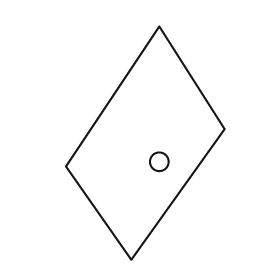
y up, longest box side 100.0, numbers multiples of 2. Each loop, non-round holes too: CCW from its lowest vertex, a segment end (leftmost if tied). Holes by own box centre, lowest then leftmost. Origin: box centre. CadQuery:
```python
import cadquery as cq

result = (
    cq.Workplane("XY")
    .moveTo(-6.0, -50.0)
    .lineTo(34.0, 6.0)
    .lineTo(6.0, 50.0)
    .lineTo(-34.0, -10.0)
    .close()
    .moveTo(6.0, -8.0)
    .circle(4.0)
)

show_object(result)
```